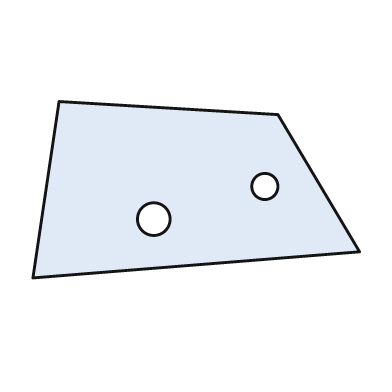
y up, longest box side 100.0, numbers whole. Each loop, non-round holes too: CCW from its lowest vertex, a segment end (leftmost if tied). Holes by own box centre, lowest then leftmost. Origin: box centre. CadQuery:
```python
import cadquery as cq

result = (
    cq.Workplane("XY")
    .moveTo(-50.0, -27.0)
    .lineTo(50.0, -19.0)
    .lineTo(25.0, 23.0)
    .lineTo(-42.0, 27.0)
    .close()
    .moveTo(-13.0, -9.0)
    .circle(5.0)
    .moveTo(21.0, 1.0)
    .circle(4.0)
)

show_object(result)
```